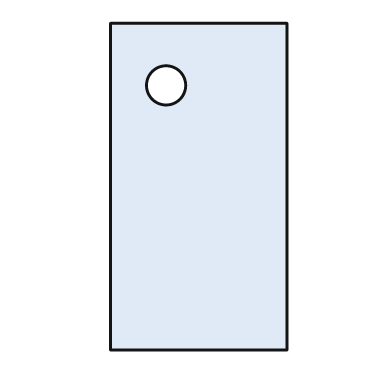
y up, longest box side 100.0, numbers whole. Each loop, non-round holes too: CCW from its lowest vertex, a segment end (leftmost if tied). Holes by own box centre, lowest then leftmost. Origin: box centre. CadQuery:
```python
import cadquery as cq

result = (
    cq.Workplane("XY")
    .moveTo(-27.0, -50.0)
    .lineTo(27.0, -50.0)
    .lineTo(27.0, 50.0)
    .lineTo(-27.0, 50.0)
    .close()
    .moveTo(-10.0, 31.0)
    .circle(6.0)
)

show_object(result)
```